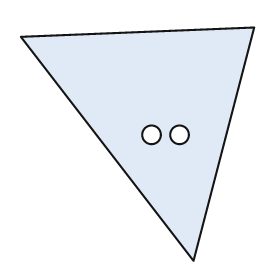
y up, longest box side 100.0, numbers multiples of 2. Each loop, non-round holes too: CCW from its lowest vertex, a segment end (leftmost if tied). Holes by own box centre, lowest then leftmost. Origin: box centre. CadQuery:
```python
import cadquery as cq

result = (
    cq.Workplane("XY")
    .moveTo(24.0, -50.0)
    .lineTo(50.0, 50.0)
    .lineTo(-50.0, 46.0)
    .close()
    .moveTo(6.0, 4.0)
    .circle(4.0)
    .moveTo(18.0, 4.0)
    .circle(4.0)
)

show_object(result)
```